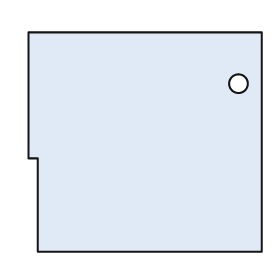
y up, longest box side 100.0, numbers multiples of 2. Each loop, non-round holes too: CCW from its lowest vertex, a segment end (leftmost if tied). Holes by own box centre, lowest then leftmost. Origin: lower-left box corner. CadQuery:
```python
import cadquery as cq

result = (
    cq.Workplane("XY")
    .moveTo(4.0, 0.0)
    .lineTo(100.0, 0.0)
    .lineTo(100.0, 94.0)
    .lineTo(0.0, 94.0)
    .lineTo(0.0, 40.0)
    .lineTo(4.0, 40.0)
    .close()
    .moveTo(90.0, 72.0)
    .circle(4.0)
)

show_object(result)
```